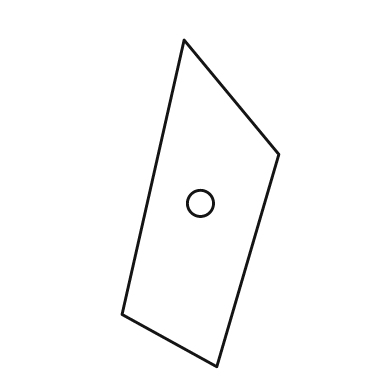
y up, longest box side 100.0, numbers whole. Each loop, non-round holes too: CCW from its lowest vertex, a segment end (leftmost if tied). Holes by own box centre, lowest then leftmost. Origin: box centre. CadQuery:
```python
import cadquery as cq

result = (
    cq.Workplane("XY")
    .moveTo(5.0, -50.0)
    .lineTo(24.0, 15.0)
    .lineTo(-5.0, 50.0)
    .lineTo(-24.0, -34.0)
    .close()
    .moveTo(0.0, 0.0)
    .circle(4.0)
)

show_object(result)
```